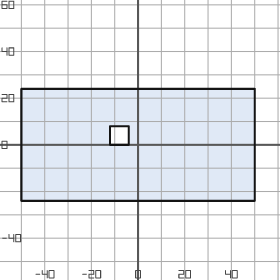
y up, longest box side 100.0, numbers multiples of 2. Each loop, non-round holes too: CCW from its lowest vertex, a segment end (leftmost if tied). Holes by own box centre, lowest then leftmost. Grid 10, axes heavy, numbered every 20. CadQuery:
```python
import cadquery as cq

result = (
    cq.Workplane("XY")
    .moveTo(-50.0, -24.0)
    .lineTo(50.0, -24.0)
    .lineTo(50.0, 24.0)
    .lineTo(-50.0, 24.0)
    .close()
    .moveTo(-12.0, 0.0)
    .lineTo(-4.0, 0.0)
    .lineTo(-4.0, 8.0)
    .lineTo(-12.0, 8.0)
    .close()
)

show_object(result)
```